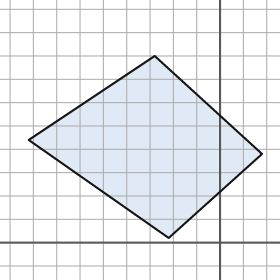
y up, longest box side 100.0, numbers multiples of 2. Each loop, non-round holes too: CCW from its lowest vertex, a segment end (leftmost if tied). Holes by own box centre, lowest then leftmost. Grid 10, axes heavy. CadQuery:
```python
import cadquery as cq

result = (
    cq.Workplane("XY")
    .moveTo(-22.0, 2.0)
    .lineTo(18.0, 38.0)
    .lineTo(-28.0, 80.0)
    .lineTo(-82.0, 44.0)
    .close()
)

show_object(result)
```